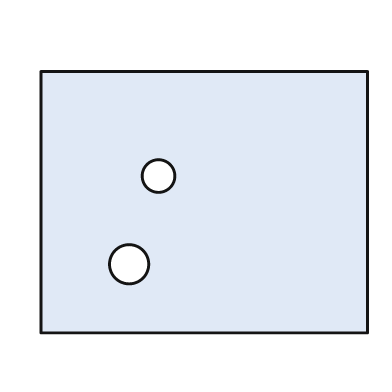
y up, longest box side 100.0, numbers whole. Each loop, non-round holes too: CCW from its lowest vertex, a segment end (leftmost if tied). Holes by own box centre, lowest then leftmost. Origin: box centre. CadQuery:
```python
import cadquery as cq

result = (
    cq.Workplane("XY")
    .moveTo(-50.0, -40.0)
    .lineTo(50.0, -40.0)
    .lineTo(50.0, 40.0)
    .lineTo(-50.0, 40.0)
    .close()
    .moveTo(-23.0, -19.0)
    .circle(6.0)
    .moveTo(-14.0, 8.0)
    .circle(5.0)
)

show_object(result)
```